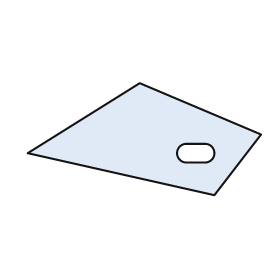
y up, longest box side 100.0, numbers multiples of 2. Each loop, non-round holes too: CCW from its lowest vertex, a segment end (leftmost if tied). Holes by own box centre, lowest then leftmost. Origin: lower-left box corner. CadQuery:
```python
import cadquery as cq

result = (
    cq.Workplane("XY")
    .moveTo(80.0, 0.0)
    .lineTo(100.0, 26.0)
    .lineTo(48.0, 48.0)
    .lineTo(0.0, 18.0)
    .close()
    .moveTo(68.0, 14.0)
    .lineTo(76.0, 14.0)
    .threePointArc((80.0, 18.0), (76.0, 22.0))
    .lineTo(68.0, 22.0)
    .threePointArc((64.0, 18.0), (68.0, 14.0))
    .close()
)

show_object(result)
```